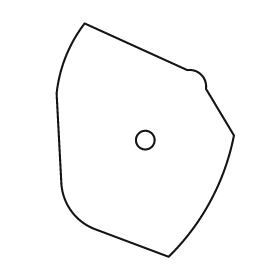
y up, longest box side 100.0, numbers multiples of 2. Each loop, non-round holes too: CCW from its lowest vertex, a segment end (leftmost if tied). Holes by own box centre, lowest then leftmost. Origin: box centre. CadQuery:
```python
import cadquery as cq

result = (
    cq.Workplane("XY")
    .moveTo(10.0, -50.0)
    .threePointArc((28.0, -26.0), (38.0, 2.0))
    .lineTo(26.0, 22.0)
    .threePointArc((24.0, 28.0), (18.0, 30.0))
    .lineTo(-26.0, 50.0)
    .threePointArc((-34.0, 36.0), (-38.0, 20.0))
    .lineTo(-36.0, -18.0)
    .threePointArc((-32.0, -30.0), (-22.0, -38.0))
    .close()
    .moveTo(0.0, 0.0)
    .circle(4.0)
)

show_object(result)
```